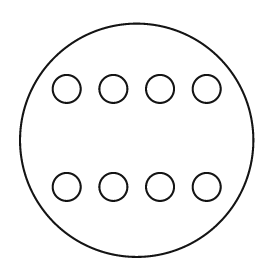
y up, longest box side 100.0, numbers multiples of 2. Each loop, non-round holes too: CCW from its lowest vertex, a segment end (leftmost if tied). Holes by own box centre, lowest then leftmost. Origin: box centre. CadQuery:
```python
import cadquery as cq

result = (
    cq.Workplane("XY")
    .moveTo(0.0, 0.0)
    .circle(50.0)
    .moveTo(-30.0, -20.0)
    .circle(6.0)
    .moveTo(-10.0, -20.0)
    .circle(6.0)
    .moveTo(10.0, -20.0)
    .circle(6.0)
    .moveTo(30.0, -20.0)
    .circle(6.0)
    .moveTo(-30.0, 22.0)
    .circle(6.0)
    .moveTo(-10.0, 22.0)
    .circle(6.0)
    .moveTo(10.0, 22.0)
    .circle(6.0)
    .moveTo(30.0, 22.0)
    .circle(6.0)
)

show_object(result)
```